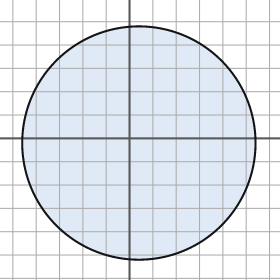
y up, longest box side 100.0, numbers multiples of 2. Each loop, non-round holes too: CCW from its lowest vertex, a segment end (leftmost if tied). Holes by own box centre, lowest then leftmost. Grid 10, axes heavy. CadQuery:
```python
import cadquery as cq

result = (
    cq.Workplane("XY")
    .moveTo(4.0, -2.0)
    .circle(50.0)
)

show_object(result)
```